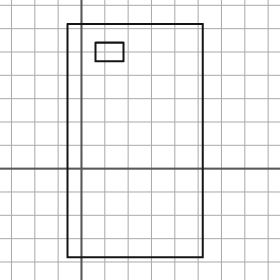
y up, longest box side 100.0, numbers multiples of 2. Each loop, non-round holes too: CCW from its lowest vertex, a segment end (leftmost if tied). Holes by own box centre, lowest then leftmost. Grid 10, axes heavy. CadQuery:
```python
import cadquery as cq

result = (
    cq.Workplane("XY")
    .moveTo(-6.0, -38.0)
    .lineTo(52.0, -38.0)
    .lineTo(52.0, 62.0)
    .lineTo(-6.0, 62.0)
    .close()
    .moveTo(6.0, 46.0)
    .lineTo(18.0, 46.0)
    .lineTo(18.0, 54.0)
    .lineTo(6.0, 54.0)
    .close()
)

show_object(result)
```